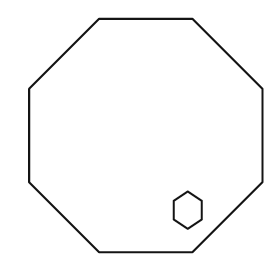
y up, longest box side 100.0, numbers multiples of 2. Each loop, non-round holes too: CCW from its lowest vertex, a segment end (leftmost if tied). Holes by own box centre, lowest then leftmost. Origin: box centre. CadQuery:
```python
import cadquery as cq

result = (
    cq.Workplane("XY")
    .moveTo(-20.0, -50.0)
    .lineTo(20.0, -50.0)
    .lineTo(50.0, -20.0)
    .lineTo(50.0, 20.0)
    .lineTo(20.0, 50.0)
    .lineTo(-20.0, 50.0)
    .lineTo(-50.0, 20.0)
    .lineTo(-50.0, -20.0)
    .close()
    .moveTo(18.0, -40.0)
    .lineTo(24.0, -36.0)
    .lineTo(24.0, -28.0)
    .lineTo(18.0, -24.0)
    .lineTo(12.0, -28.0)
    .lineTo(12.0, -36.0)
    .close()
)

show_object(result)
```